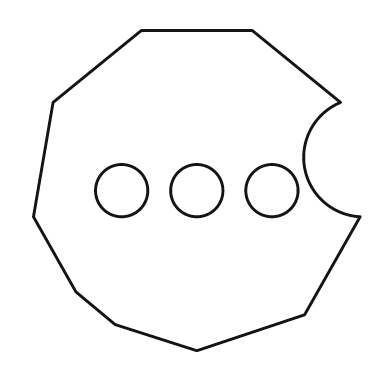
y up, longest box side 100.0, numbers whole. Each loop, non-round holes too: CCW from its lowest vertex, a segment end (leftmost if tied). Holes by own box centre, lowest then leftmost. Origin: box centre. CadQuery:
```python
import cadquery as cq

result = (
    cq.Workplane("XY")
    .moveTo(0.0, -49.0)
    .lineTo(33.0, -38.0)
    .lineTo(50.0, -8.0)
    .threePointArc((33.0, 7.0), (44.0, 27.0))
    .lineTo(17.0, 49.0)
    .lineTo(-17.0, 49.0)
    .lineTo(-44.0, 27.0)
    .lineTo(-50.0, -8.0)
    .lineTo(-37.0, -31.0)
    .lineTo(-25.0, -41.0)
    .close()
    .moveTo(-23.0, 0.0)
    .circle(8.0)
    .moveTo(0.0, 0.0)
    .circle(8.0)
    .moveTo(23.0, 0.0)
    .circle(8.0)
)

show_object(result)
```